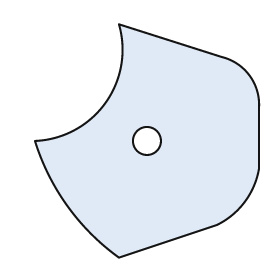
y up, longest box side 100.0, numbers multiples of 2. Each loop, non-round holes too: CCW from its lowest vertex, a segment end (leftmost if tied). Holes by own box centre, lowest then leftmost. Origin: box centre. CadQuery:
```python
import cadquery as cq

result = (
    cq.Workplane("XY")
    .moveTo(-12.0, -50.0)
    .lineTo(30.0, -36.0)
    .threePointArc((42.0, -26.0), (48.0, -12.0))
    .lineTo(48.0, 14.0)
    .threePointArc((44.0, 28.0), (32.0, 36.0))
    .lineTo(-12.0, 50.0)
    .threePointArc((-18.0, 16.0), (-48.0, 0.0))
    .threePointArc((-34.0, -28.0), (-12.0, -50.0))
    .close()
    .moveTo(0.0, 0.0)
    .circle(6.0)
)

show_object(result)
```